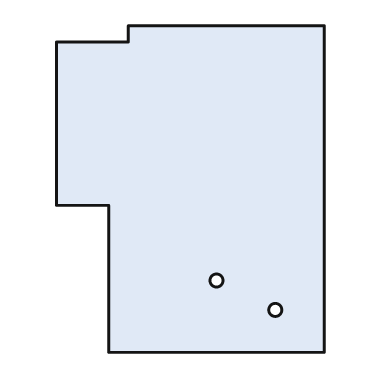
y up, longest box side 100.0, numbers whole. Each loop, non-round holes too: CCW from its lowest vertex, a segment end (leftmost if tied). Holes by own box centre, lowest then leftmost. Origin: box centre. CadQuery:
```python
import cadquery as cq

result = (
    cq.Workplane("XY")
    .moveTo(-25.0, -50.0)
    .lineTo(41.0, -50.0)
    .lineTo(41.0, 50.0)
    .lineTo(-19.0, 50.0)
    .lineTo(-19.0, 45.0)
    .lineTo(-41.0, 45.0)
    .lineTo(-41.0, -5.0)
    .lineTo(-25.0, -5.0)
    .close()
    .moveTo(26.0, -37.0)
    .circle(2.0)
    .moveTo(8.0, -28.0)
    .circle(2.0)
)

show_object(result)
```